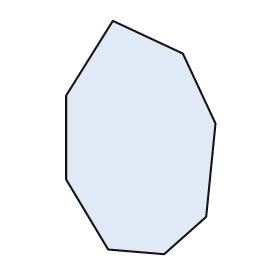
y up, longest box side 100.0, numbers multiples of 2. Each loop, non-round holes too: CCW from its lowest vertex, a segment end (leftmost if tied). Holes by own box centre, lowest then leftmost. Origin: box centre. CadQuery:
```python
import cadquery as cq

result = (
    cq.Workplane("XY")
    .moveTo(10.0, -50.0)
    .lineTo(28.0, -34.0)
    .lineTo(32.0, 6.0)
    .lineTo(18.0, 36.0)
    .lineTo(-12.0, 50.0)
    .lineTo(-32.0, 18.0)
    .lineTo(-32.0, -18.0)
    .lineTo(-14.0, -48.0)
    .close()
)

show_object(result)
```